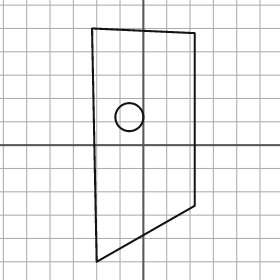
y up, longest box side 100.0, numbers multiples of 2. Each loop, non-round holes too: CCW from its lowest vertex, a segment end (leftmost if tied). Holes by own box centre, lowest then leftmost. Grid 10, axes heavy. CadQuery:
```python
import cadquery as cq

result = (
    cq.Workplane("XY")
    .moveTo(-20.0, -50.0)
    .lineTo(22.0, -26.0)
    .lineTo(22.0, 48.0)
    .lineTo(-22.0, 50.0)
    .close()
    .moveTo(-6.0, 12.0)
    .circle(6.0)
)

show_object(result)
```